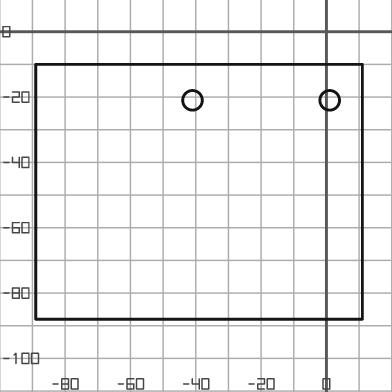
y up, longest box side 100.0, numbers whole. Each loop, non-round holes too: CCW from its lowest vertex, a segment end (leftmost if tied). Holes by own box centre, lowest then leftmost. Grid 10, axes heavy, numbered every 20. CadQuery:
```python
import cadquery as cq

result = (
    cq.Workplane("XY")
    .moveTo(-89.0, -88.0)
    .lineTo(11.0, -88.0)
    .lineTo(11.0, -10.0)
    .lineTo(-89.0, -10.0)
    .close()
    .moveTo(-41.0, -21.0)
    .circle(3.0)
    .moveTo(1.0, -21.0)
    .circle(3.0)
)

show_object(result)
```